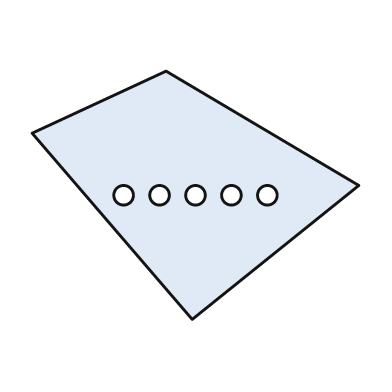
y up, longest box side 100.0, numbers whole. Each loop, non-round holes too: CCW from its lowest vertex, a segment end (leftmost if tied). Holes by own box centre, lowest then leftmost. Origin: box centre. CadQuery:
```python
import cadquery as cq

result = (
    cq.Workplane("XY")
    .moveTo(-1.0, -38.0)
    .lineTo(50.0, 3.0)
    .lineTo(-9.0, 38.0)
    .lineTo(-50.0, 19.0)
    .close()
    .moveTo(-22.0, 0.0)
    .circle(3.0)
    .moveTo(-11.0, 0.0)
    .circle(3.0)
    .moveTo(0.0, 0.0)
    .circle(3.0)
    .moveTo(11.0, 0.0)
    .circle(3.0)
    .moveTo(22.0, 0.0)
    .circle(3.0)
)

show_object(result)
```